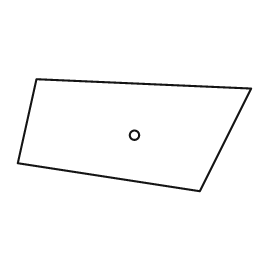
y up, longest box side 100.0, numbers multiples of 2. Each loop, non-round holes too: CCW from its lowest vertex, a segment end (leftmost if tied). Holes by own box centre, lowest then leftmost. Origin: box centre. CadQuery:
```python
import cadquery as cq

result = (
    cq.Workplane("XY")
    .moveTo(28.0, -24.0)
    .lineTo(50.0, 20.0)
    .lineTo(-42.0, 24.0)
    .lineTo(-50.0, -12.0)
    .close()
    .moveTo(0.0, 0.0)
    .circle(2.0)
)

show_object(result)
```